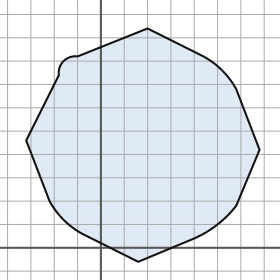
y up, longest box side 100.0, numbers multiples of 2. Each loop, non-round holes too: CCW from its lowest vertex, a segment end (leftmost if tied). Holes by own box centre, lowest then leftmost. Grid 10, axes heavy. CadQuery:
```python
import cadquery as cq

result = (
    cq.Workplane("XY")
    .moveTo(16.0, -6.0)
    .lineTo(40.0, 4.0)
    .threePointArc((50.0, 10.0), (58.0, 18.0))
    .lineTo(68.0, 42.0)
    .lineTo(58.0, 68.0)
    .threePointArc((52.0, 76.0), (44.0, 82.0))
    .lineTo(20.0, 94.0)
    .lineTo(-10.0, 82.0)
    .threePointArc((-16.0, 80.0), (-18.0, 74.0))
    .lineTo(-32.0, 46.0)
    .lineTo(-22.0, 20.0)
    .threePointArc((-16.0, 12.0), (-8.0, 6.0))
    .close()
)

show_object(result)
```